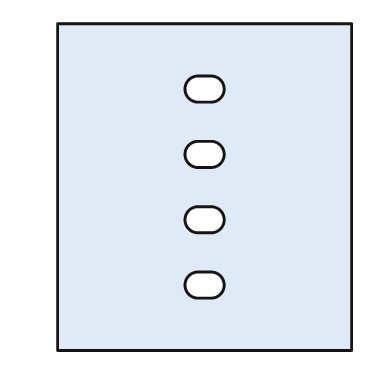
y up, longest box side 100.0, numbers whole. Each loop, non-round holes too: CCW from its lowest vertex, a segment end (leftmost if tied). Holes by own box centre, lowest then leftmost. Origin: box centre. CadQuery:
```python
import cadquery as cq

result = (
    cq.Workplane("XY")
    .moveTo(-45.0, -50.0)
    .lineTo(45.0, -50.0)
    .lineTo(45.0, 50.0)
    .lineTo(-45.0, 50.0)
    .close()
    .moveTo(-2.0, -34.0)
    .lineTo(2.0, -34.0)
    .threePointArc((6.0, -30.0), (2.0, -26.0))
    .lineTo(-2.0, -26.0)
    .threePointArc((-6.0, -30.0), (-2.0, -34.0))
    .close()
    .moveTo(-2.0, -14.0)
    .lineTo(2.0, -14.0)
    .threePointArc((6.0, -10.0), (2.0, -6.0))
    .lineTo(-2.0, -6.0)
    .threePointArc((-6.0, -10.0), (-2.0, -14.0))
    .close()
    .moveTo(-2.0, 6.0)
    .lineTo(2.0, 6.0)
    .threePointArc((6.0, 10.0), (2.0, 14.0))
    .lineTo(-2.0, 14.0)
    .threePointArc((-6.0, 10.0), (-2.0, 6.0))
    .close()
    .moveTo(-2.0, 26.0)
    .lineTo(2.0, 26.0)
    .threePointArc((6.0, 30.0), (2.0, 34.0))
    .lineTo(-2.0, 34.0)
    .threePointArc((-6.0, 30.0), (-2.0, 26.0))
    .close()
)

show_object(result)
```